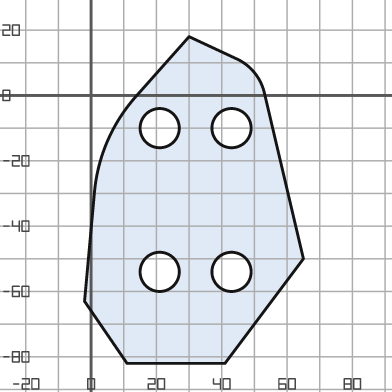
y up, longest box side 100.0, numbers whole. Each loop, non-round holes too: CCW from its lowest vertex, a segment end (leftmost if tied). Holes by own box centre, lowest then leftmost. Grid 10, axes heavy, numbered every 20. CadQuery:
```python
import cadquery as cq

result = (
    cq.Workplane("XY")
    .moveTo(11.0, -82.0)
    .lineTo(41.0, -82.0)
    .lineTo(65.0, -50.0)
    .lineTo(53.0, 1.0)
    .threePointArc((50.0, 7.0), (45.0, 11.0))
    .lineTo(30.0, 18.0)
    .lineTo(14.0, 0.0)
    .threePointArc((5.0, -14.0), (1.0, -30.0))
    .lineTo(-2.0, -63.0)
    .close()
    .moveTo(21.0, -54.0)
    .circle(6.0)
    .moveTo(43.0, -54.0)
    .circle(6.0)
    .moveTo(21.0, -10.0)
    .circle(6.0)
    .moveTo(43.0, -10.0)
    .circle(6.0)
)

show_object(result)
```